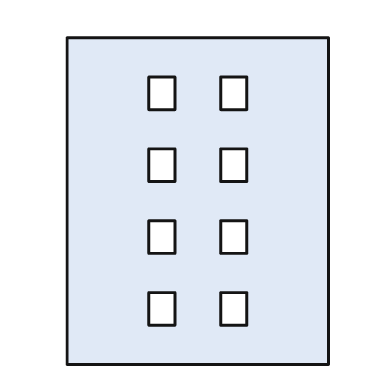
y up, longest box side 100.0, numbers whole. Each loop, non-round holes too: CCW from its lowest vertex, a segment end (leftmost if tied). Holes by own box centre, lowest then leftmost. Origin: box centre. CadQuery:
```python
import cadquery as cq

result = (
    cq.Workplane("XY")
    .moveTo(-40.0, -50.0)
    .lineTo(40.0, -50.0)
    .lineTo(40.0, 50.0)
    .lineTo(-40.0, 50.0)
    .close()
    .moveTo(-15.0, -38.0)
    .lineTo(-7.0, -38.0)
    .lineTo(-7.0, -28.0)
    .lineTo(-15.0, -28.0)
    .close()
    .moveTo(7.0, -38.0)
    .lineTo(15.0, -38.0)
    .lineTo(15.0, -28.0)
    .lineTo(7.0, -28.0)
    .close()
    .moveTo(-15.0, -16.0)
    .lineTo(-7.0, -16.0)
    .lineTo(-7.0, -6.0)
    .lineTo(-15.0, -6.0)
    .close()
    .moveTo(7.0, -16.0)
    .lineTo(15.0, -16.0)
    .lineTo(15.0, -6.0)
    .lineTo(7.0, -6.0)
    .close()
    .moveTo(-15.0, 6.0)
    .lineTo(-7.0, 6.0)
    .lineTo(-7.0, 16.0)
    .lineTo(-15.0, 16.0)
    .close()
    .moveTo(7.0, 6.0)
    .lineTo(15.0, 6.0)
    .lineTo(15.0, 16.0)
    .lineTo(7.0, 16.0)
    .close()
    .moveTo(-15.0, 28.0)
    .lineTo(-7.0, 28.0)
    .lineTo(-7.0, 38.0)
    .lineTo(-15.0, 38.0)
    .close()
    .moveTo(7.0, 28.0)
    .lineTo(15.0, 28.0)
    .lineTo(15.0, 38.0)
    .lineTo(7.0, 38.0)
    .close()
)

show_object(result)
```